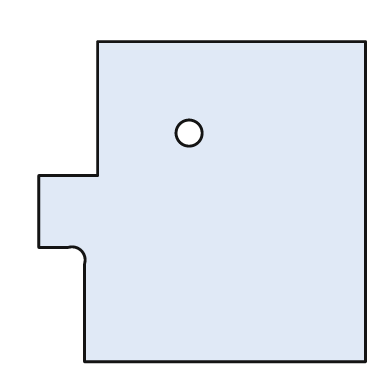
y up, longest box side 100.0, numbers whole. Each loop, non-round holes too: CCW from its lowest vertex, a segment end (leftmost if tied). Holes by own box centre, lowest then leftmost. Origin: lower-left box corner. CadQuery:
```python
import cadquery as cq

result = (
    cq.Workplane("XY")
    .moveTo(14.0, 0.0)
    .lineTo(100.0, 0.0)
    .lineTo(100.0, 98.0)
    .lineTo(18.0, 98.0)
    .lineTo(18.0, 57.0)
    .lineTo(0.0, 57.0)
    .lineTo(0.0, 35.0)
    .lineTo(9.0, 35.0)
    .threePointArc((13.0, 34.0), (14.0, 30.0))
    .close()
    .moveTo(46.0, 70.0)
    .circle(4.0)
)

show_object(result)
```